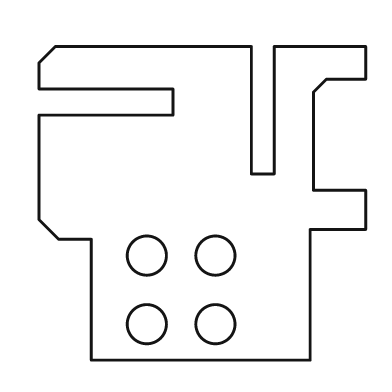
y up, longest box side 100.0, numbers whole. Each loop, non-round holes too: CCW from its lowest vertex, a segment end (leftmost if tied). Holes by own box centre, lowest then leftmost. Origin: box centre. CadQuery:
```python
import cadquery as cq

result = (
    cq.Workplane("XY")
    .moveTo(-34.0, -48.0)
    .lineTo(33.0, -48.0)
    .lineTo(33.0, -8.0)
    .lineTo(50.0, -8.0)
    .lineTo(50.0, 4.0)
    .lineTo(34.0, 4.0)
    .lineTo(34.0, 34.0)
    .lineTo(38.0, 38.0)
    .lineTo(50.0, 38.0)
    .lineTo(50.0, 48.0)
    .lineTo(22.0, 48.0)
    .lineTo(22.0, 9.0)
    .lineTo(15.0, 9.0)
    .lineTo(15.0, 48.0)
    .lineTo(-45.0, 48.0)
    .lineTo(-50.0, 43.0)
    .lineTo(-50.0, 35.0)
    .lineTo(-9.0, 35.0)
    .lineTo(-9.0, 27.0)
    .lineTo(-50.0, 27.0)
    .lineTo(-50.0, -5.0)
    .lineTo(-44.0, -11.0)
    .lineTo(-34.0, -11.0)
    .close()
    .moveTo(-17.0, -37.0)
    .circle(6.0)
    .moveTo(4.0, -37.0)
    .circle(6.0)
    .moveTo(-17.0, -16.0)
    .circle(6.0)
    .moveTo(4.0, -16.0)
    .circle(6.0)
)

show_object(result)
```